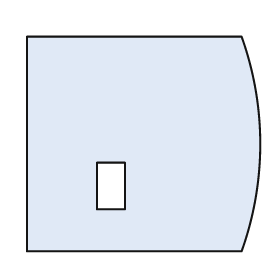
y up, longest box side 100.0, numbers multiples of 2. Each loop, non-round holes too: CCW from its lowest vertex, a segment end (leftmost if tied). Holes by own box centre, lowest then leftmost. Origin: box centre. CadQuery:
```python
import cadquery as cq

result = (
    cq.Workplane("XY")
    .moveTo(-50.0, -46.0)
    .lineTo(42.0, -46.0)
    .threePointArc((50.0, 0.0), (42.0, 46.0))
    .lineTo(-50.0, 46.0)
    .close()
    .moveTo(-20.0, -28.0)
    .lineTo(-8.0, -28.0)
    .lineTo(-8.0, -8.0)
    .lineTo(-20.0, -8.0)
    .close()
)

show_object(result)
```